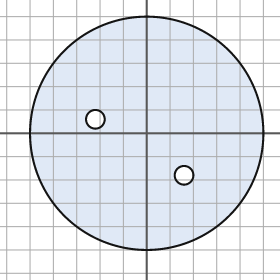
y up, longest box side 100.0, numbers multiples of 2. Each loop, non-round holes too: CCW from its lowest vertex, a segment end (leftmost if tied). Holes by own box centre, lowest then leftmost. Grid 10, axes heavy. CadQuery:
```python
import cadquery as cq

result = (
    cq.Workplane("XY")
    .moveTo(0.0, 0.0)
    .circle(50.0)
    .moveTo(16.0, -18.0)
    .circle(4.0)
    .moveTo(-22.0, 6.0)
    .circle(4.0)
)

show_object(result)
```